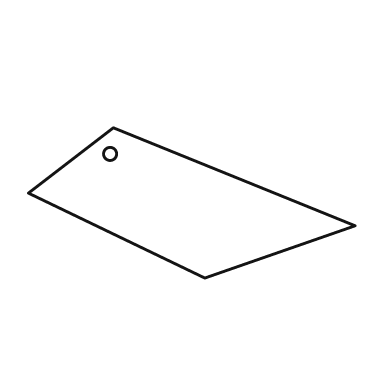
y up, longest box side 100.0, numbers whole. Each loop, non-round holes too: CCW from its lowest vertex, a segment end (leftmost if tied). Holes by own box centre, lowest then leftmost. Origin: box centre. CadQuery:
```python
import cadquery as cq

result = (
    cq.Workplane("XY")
    .moveTo(4.0, -23.0)
    .lineTo(50.0, -7.0)
    .lineTo(-24.0, 23.0)
    .lineTo(-50.0, 3.0)
    .close()
    .moveTo(-25.0, 15.0)
    .circle(2.0)
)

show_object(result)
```